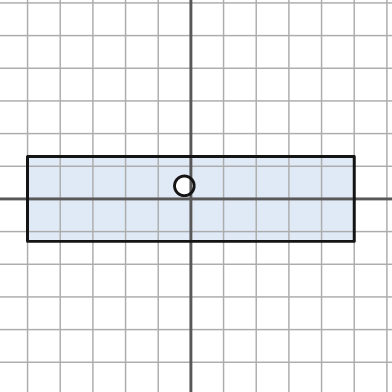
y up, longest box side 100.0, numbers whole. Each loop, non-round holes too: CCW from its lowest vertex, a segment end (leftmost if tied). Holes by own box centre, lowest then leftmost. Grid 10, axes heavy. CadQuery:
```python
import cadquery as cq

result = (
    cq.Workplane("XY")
    .moveTo(-50.0, -13.0)
    .lineTo(50.0, -13.0)
    .lineTo(50.0, 13.0)
    .lineTo(-50.0, 13.0)
    .close()
    .moveTo(-2.0, 4.0)
    .circle(3.0)
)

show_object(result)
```